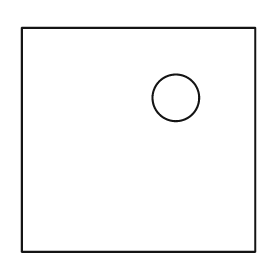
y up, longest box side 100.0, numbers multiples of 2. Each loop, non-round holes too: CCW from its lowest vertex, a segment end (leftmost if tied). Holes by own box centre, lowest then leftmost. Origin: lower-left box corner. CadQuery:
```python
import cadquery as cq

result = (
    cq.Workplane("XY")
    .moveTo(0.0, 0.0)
    .lineTo(100.0, 0.0)
    .lineTo(100.0, 96.0)
    .lineTo(0.0, 96.0)
    .close()
    .moveTo(66.0, 66.0)
    .circle(10.0)
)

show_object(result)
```